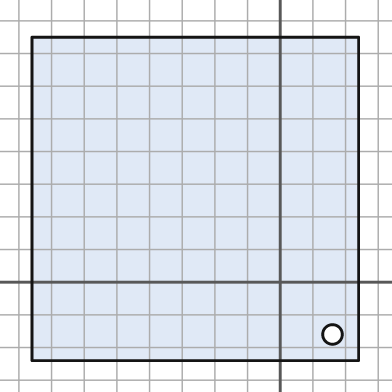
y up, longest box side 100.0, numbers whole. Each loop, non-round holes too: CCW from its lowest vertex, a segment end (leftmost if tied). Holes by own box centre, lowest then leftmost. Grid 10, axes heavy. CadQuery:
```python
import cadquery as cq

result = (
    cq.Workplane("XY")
    .moveTo(-76.0, -24.0)
    .lineTo(24.0, -24.0)
    .lineTo(24.0, 75.0)
    .lineTo(-76.0, 75.0)
    .close()
    .moveTo(16.0, -16.0)
    .circle(3.0)
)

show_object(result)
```